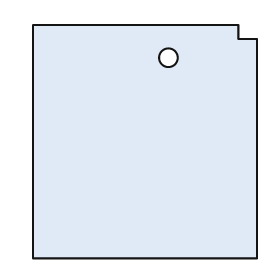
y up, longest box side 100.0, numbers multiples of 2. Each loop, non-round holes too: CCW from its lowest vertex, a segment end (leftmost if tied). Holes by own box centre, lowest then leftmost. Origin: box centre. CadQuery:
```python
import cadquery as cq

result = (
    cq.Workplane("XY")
    .moveTo(-48.0, -50.0)
    .lineTo(48.0, -50.0)
    .lineTo(48.0, 44.0)
    .lineTo(40.0, 44.0)
    .lineTo(40.0, 50.0)
    .lineTo(-48.0, 50.0)
    .close()
    .moveTo(10.0, 36.0)
    .circle(4.0)
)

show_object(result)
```